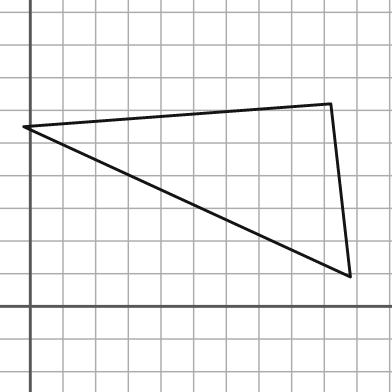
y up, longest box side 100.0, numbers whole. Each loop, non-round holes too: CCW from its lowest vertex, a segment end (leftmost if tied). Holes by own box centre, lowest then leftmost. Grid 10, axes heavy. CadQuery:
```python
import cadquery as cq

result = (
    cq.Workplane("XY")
    .moveTo(98.0, 9.0)
    .lineTo(92.0, 62.0)
    .lineTo(-2.0, 55.0)
    .close()
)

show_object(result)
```